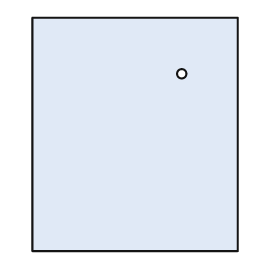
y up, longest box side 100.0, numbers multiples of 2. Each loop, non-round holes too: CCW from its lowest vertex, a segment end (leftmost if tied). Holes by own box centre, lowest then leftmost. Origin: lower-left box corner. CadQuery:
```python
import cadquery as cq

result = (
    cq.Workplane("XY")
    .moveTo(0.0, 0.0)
    .lineTo(88.0, 0.0)
    .lineTo(88.0, 100.0)
    .lineTo(0.0, 100.0)
    .close()
    .moveTo(64.0, 76.0)
    .circle(2.0)
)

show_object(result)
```